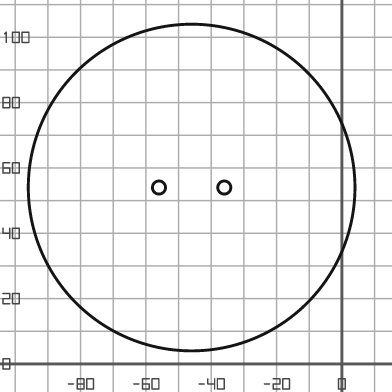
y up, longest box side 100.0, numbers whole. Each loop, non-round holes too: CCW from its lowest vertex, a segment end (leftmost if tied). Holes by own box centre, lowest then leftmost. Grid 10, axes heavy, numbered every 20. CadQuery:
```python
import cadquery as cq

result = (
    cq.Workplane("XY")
    .moveTo(-46.0, 54.0)
    .circle(50.0)
    .moveTo(-56.0, 54.0)
    .circle(2.0)
    .moveTo(-36.0, 54.0)
    .circle(2.0)
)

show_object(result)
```